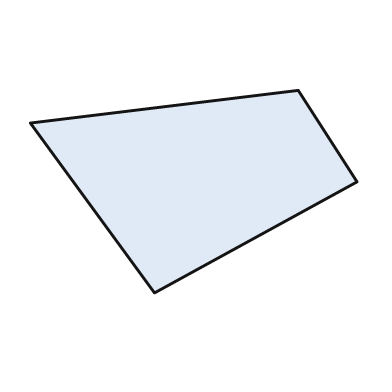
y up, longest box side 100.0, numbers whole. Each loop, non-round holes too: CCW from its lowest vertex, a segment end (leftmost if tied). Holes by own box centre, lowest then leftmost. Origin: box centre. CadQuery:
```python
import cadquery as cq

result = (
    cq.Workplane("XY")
    .moveTo(-12.0, -31.0)
    .lineTo(50.0, 3.0)
    .lineTo(32.0, 31.0)
    .lineTo(-50.0, 21.0)
    .close()
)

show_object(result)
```